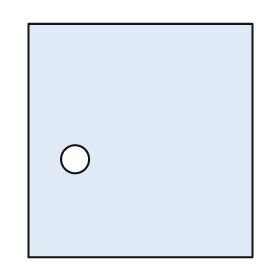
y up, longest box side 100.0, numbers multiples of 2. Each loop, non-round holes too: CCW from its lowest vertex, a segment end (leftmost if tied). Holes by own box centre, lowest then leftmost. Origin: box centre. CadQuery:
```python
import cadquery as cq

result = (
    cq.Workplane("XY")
    .moveTo(-48.0, -50.0)
    .lineTo(48.0, -50.0)
    .lineTo(48.0, 50.0)
    .lineTo(-48.0, 50.0)
    .close()
    .moveTo(-28.0, -8.0)
    .circle(6.0)
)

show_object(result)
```